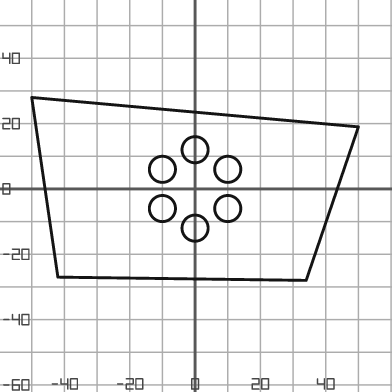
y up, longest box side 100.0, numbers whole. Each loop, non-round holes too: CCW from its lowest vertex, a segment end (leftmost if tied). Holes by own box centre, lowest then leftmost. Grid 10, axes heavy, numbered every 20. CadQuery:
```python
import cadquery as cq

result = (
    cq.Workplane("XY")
    .moveTo(34.0, -28.0)
    .lineTo(50.0, 19.0)
    .lineTo(-50.0, 28.0)
    .lineTo(-42.0, -27.0)
    .close()
    .moveTo(0.0, -12.0)
    .circle(4.0)
    .moveTo(-10.0, -6.0)
    .circle(4.0)
    .moveTo(10.0, -6.0)
    .circle(4.0)
    .moveTo(-10.0, 6.0)
    .circle(4.0)
    .moveTo(10.0, 6.0)
    .circle(4.0)
    .moveTo(0.0, 12.0)
    .circle(4.0)
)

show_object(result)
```